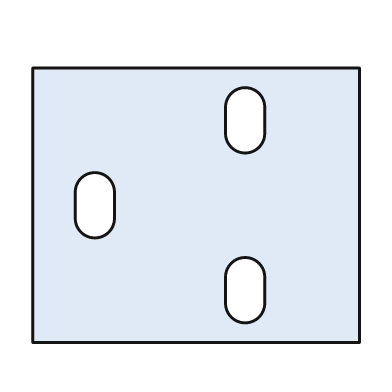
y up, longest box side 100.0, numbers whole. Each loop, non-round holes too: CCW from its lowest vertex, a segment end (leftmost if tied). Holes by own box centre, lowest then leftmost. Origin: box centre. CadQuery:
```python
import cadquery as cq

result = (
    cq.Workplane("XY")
    .moveTo(-50.0, -42.0)
    .lineTo(50.0, -42.0)
    .lineTo(50.0, 42.0)
    .lineTo(-50.0, 42.0)
    .close()
    .moveTo(9.0, -30.0)
    .threePointArc((15.0, -36.0), (21.0, -30.0))
    .lineTo(21.0, -22.0)
    .threePointArc((15.0, -16.0), (9.0, -22.0))
    .close()
    .moveTo(-37.0, -4.0)
    .threePointArc((-31.0, -10.0), (-25.0, -4.0))
    .lineTo(-25.0, 4.0)
    .threePointArc((-31.0, 10.0), (-37.0, 4.0))
    .close()
    .moveTo(9.0, 22.0)
    .threePointArc((15.0, 16.0), (21.0, 22.0))
    .lineTo(21.0, 30.0)
    .threePointArc((15.0, 36.0), (9.0, 30.0))
    .close()
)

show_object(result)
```